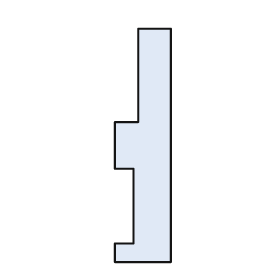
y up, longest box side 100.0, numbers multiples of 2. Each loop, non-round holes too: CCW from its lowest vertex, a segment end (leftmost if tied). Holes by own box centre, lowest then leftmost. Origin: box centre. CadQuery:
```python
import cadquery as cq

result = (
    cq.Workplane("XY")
    .moveTo(-12.0, -50.0)
    .lineTo(12.0, -50.0)
    .lineTo(12.0, 50.0)
    .lineTo(-2.0, 50.0)
    .lineTo(-2.0, 10.0)
    .lineTo(-12.0, 10.0)
    .lineTo(-12.0, -10.0)
    .lineTo(-4.0, -10.0)
    .lineTo(-4.0, -42.0)
    .lineTo(-12.0, -42.0)
    .close()
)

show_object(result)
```